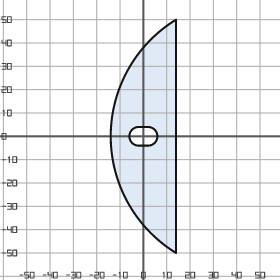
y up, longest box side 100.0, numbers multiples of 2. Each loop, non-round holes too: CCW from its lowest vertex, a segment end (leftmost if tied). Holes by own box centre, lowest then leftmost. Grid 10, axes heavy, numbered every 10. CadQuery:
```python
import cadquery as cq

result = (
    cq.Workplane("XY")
    .moveTo(14.0, -50.0)
    .lineTo(14.0, 50.0)
    .threePointArc((-14.0, 0.0), (14.0, -50.0))
    .close()
    .moveTo(-2.0, -4.0)
    .lineTo(2.0, -4.0)
    .threePointArc((6.0, 0.0), (2.0, 4.0))
    .lineTo(-2.0, 4.0)
    .threePointArc((-6.0, 0.0), (-2.0, -4.0))
    .close()
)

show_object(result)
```